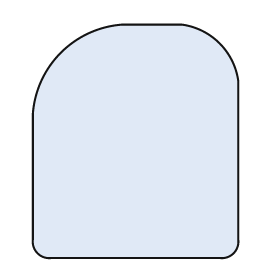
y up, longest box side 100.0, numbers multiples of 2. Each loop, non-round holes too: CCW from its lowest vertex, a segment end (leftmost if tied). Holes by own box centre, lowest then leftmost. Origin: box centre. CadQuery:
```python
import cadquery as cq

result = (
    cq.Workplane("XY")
    .moveTo(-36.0, -50.0)
    .lineTo(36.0, -50.0)
    .threePointArc((42.0, -48.0), (44.0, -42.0))
    .lineTo(44.0, 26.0)
    .threePointArc((36.0, 42.0), (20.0, 50.0))
    .lineTo(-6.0, 50.0)
    .threePointArc((-32.0, 38.0), (-44.0, 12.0))
    .lineTo(-44.0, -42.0)
    .threePointArc((-42.0, -48.0), (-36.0, -50.0))
    .close()
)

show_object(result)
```